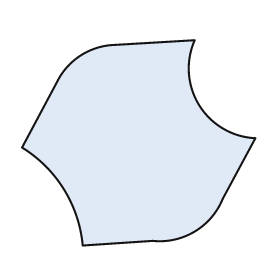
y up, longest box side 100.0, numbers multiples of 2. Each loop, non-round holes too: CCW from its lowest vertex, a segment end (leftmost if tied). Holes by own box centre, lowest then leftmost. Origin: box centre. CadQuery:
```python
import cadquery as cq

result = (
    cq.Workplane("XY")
    .moveTo(-24.0, -44.0)
    .lineTo(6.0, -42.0)
    .threePointArc((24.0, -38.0), (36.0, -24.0))
    .lineTo(50.0, 2.0)
    .threePointArc((26.0, 16.0), (24.0, 44.0))
    .lineTo(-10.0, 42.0)
    .threePointArc((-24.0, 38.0), (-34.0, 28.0))
    .lineTo(-50.0, -2.0)
    .threePointArc((-32.0, -20.0), (-24.0, -44.0))
    .close()
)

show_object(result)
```